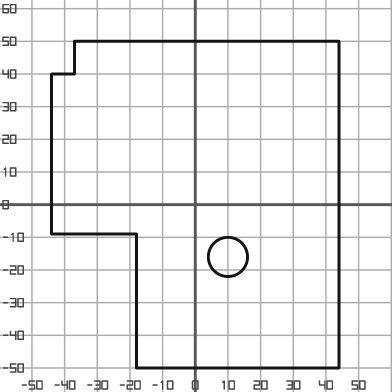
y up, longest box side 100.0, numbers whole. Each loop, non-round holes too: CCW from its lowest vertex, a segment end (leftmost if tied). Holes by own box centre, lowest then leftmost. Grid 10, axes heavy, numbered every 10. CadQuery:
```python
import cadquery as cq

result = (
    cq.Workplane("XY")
    .moveTo(-18.0, -50.0)
    .lineTo(44.0, -50.0)
    .lineTo(44.0, 50.0)
    .lineTo(-37.0, 50.0)
    .lineTo(-37.0, 40.0)
    .lineTo(-44.0, 40.0)
    .lineTo(-44.0, -9.0)
    .lineTo(-18.0, -9.0)
    .close()
    .moveTo(10.0, -16.0)
    .circle(6.0)
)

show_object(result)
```